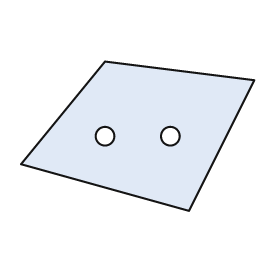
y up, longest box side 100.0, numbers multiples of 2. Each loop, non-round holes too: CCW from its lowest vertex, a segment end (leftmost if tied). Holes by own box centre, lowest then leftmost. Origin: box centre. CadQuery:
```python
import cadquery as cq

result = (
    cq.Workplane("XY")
    .moveTo(22.0, -32.0)
    .lineTo(50.0, 24.0)
    .lineTo(-14.0, 32.0)
    .lineTo(-50.0, -12.0)
    .close()
    .moveTo(-14.0, 0.0)
    .circle(4.0)
    .moveTo(14.0, 0.0)
    .circle(4.0)
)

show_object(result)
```